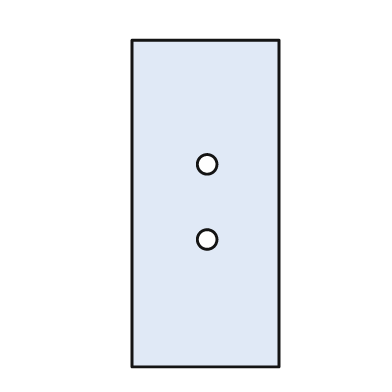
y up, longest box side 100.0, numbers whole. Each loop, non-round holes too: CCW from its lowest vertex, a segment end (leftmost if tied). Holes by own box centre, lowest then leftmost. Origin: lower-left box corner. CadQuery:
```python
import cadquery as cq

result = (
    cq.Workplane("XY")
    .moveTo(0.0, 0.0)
    .lineTo(45.0, 0.0)
    .lineTo(45.0, 100.0)
    .lineTo(0.0, 100.0)
    .close()
    .moveTo(23.0, 39.0)
    .circle(3.0)
    .moveTo(23.0, 62.0)
    .circle(3.0)
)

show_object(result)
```